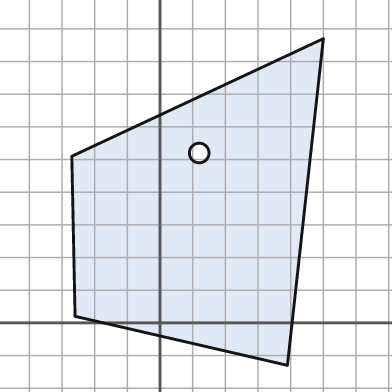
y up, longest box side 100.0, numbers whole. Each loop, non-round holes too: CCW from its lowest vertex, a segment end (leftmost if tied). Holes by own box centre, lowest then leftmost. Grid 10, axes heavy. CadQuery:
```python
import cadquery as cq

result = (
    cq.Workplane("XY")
    .moveTo(39.0, -13.0)
    .lineTo(50.0, 87.0)
    .lineTo(-27.0, 51.0)
    .lineTo(-26.0, 2.0)
    .close()
    .moveTo(12.0, 52.0)
    .circle(3.0)
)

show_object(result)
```